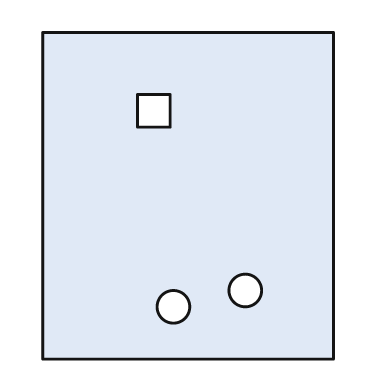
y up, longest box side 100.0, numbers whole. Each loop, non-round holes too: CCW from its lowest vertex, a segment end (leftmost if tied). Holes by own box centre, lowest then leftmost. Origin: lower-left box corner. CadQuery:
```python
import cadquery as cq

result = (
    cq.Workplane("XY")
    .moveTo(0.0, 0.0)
    .lineTo(89.0, 0.0)
    .lineTo(89.0, 100.0)
    .lineTo(0.0, 100.0)
    .close()
    .moveTo(40.0, 16.0)
    .circle(5.0)
    .moveTo(62.0, 21.0)
    .circle(5.0)
    .moveTo(29.0, 71.0)
    .lineTo(39.0, 71.0)
    .lineTo(39.0, 81.0)
    .lineTo(29.0, 81.0)
    .close()
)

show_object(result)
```